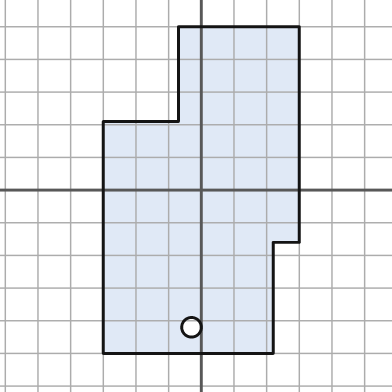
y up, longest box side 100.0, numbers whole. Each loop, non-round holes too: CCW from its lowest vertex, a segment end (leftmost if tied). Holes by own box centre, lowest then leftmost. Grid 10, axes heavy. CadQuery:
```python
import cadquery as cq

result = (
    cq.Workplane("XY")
    .moveTo(-30.0, -50.0)
    .lineTo(22.0, -50.0)
    .lineTo(22.0, -16.0)
    .lineTo(30.0, -16.0)
    .lineTo(30.0, 50.0)
    .lineTo(-7.0, 50.0)
    .lineTo(-7.0, 21.0)
    .lineTo(-30.0, 21.0)
    .close()
    .moveTo(-3.0, -42.0)
    .circle(3.0)
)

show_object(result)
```